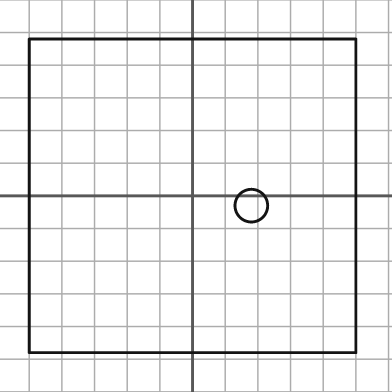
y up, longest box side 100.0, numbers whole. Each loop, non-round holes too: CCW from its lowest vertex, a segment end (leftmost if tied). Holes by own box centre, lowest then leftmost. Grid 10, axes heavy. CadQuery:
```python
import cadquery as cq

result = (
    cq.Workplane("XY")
    .moveTo(-50.0, -48.0)
    .lineTo(50.0, -48.0)
    .lineTo(50.0, 48.0)
    .lineTo(-50.0, 48.0)
    .close()
    .moveTo(18.0, -3.0)
    .circle(5.0)
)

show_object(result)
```